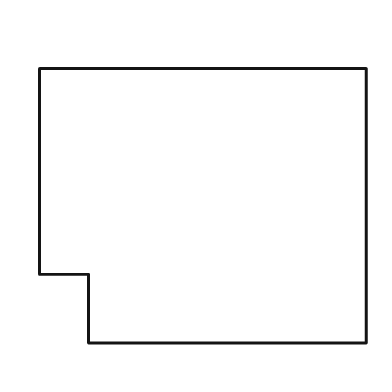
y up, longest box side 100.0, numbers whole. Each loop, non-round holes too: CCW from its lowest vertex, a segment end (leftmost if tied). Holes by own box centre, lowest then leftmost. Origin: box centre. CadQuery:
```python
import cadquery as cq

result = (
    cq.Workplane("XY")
    .moveTo(-35.0, -42.0)
    .lineTo(50.0, -42.0)
    .lineTo(50.0, 42.0)
    .lineTo(-50.0, 42.0)
    .lineTo(-50.0, -21.0)
    .lineTo(-35.0, -21.0)
    .close()
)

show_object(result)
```